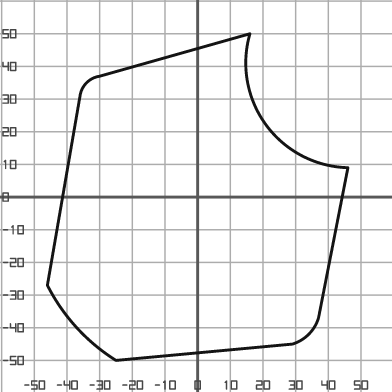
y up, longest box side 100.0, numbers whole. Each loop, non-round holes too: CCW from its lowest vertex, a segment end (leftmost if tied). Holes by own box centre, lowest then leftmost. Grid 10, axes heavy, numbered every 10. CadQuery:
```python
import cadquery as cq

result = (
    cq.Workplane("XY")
    .moveTo(-25.0, -50.0)
    .lineTo(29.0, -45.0)
    .threePointArc((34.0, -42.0), (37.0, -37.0))
    .lineTo(46.0, 9.0)
    .threePointArc((21.0, 22.0), (16.0, 50.0))
    .lineTo(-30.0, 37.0)
    .threePointArc((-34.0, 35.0), (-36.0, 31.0))
    .lineTo(-46.0, -27.0)
    .threePointArc((-37.0, -40.0), (-25.0, -50.0))
    .close()
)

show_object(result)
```